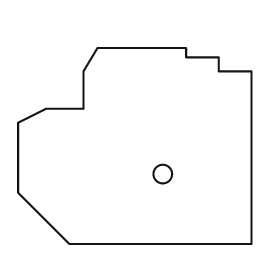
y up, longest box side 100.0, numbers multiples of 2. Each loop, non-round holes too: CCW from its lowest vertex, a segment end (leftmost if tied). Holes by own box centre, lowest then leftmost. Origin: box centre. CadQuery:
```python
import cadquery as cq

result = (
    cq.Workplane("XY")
    .moveTo(-28.0, -42.0)
    .lineTo(50.0, -42.0)
    .lineTo(50.0, 32.0)
    .lineTo(36.0, 32.0)
    .lineTo(36.0, 38.0)
    .lineTo(22.0, 38.0)
    .lineTo(22.0, 42.0)
    .lineTo(-16.0, 42.0)
    .lineTo(-22.0, 32.0)
    .lineTo(-22.0, 16.0)
    .lineTo(-38.0, 16.0)
    .lineTo(-50.0, 10.0)
    .lineTo(-50.0, -20.0)
    .close()
    .moveTo(12.0, -12.0)
    .circle(4.0)
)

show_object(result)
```